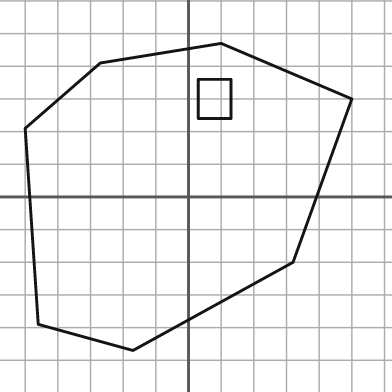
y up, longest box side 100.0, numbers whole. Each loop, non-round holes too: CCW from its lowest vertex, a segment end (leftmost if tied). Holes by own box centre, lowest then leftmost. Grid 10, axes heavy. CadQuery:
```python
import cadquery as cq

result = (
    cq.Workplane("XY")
    .moveTo(-17.0, -47.0)
    .lineTo(32.0, -20.0)
    .lineTo(50.0, 30.0)
    .lineTo(10.0, 47.0)
    .lineTo(-27.0, 41.0)
    .lineTo(-50.0, 21.0)
    .lineTo(-46.0, -39.0)
    .close()
    .moveTo(3.0, 24.0)
    .lineTo(13.0, 24.0)
    .lineTo(13.0, 36.0)
    .lineTo(3.0, 36.0)
    .close()
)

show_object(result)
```